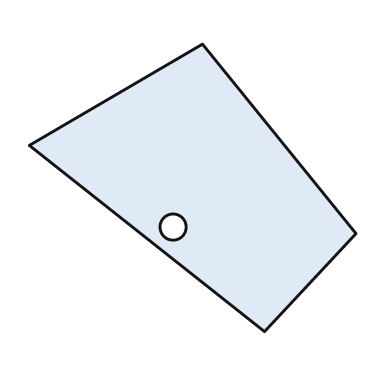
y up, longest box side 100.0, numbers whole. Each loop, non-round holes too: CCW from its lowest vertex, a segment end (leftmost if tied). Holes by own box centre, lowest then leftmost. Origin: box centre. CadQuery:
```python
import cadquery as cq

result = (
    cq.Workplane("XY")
    .moveTo(22.0, -44.0)
    .lineTo(50.0, -14.0)
    .lineTo(3.0, 44.0)
    .lineTo(-50.0, 13.0)
    .close()
    .moveTo(-6.0, -12.0)
    .circle(4.0)
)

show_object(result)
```